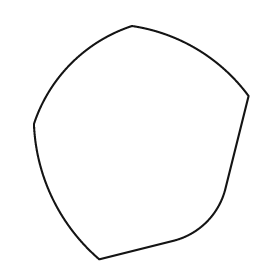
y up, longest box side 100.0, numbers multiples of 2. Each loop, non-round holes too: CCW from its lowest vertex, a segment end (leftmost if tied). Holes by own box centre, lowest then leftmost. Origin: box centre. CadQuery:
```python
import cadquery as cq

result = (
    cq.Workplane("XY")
    .moveTo(-18.0, -50.0)
    .lineTo(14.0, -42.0)
    .threePointArc((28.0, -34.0), (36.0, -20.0))
    .lineTo(46.0, 20.0)
    .threePointArc((24.0, 40.0), (-4.0, 50.0))
    .threePointArc((-30.0, 34.0), (-46.0, 8.0))
    .threePointArc((-38.0, -24.0), (-18.0, -50.0))
    .close()
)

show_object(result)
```